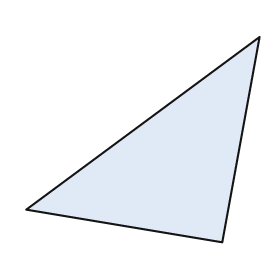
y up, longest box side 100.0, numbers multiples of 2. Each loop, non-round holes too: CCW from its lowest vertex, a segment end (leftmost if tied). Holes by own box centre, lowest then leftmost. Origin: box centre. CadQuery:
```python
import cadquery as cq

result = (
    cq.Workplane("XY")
    .moveTo(34.0, -44.0)
    .lineTo(50.0, 44.0)
    .lineTo(-50.0, -30.0)
    .close()
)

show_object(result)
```